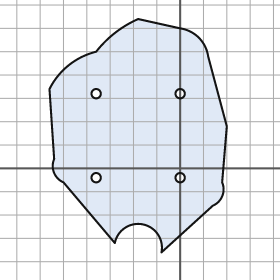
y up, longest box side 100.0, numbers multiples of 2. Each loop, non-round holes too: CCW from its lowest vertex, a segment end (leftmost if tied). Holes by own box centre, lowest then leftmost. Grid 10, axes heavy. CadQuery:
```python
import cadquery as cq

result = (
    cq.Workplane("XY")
    .moveTo(-8.0, -36.0)
    .lineTo(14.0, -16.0)
    .threePointArc((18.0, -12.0), (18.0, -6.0))
    .lineTo(20.0, 18.0)
    .lineTo(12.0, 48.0)
    .threePointArc((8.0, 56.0), (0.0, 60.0))
    .lineTo(-18.0, 64.0)
    .threePointArc((-28.0, 58.0), (-36.0, 50.0))
    .threePointArc((-48.0, 44.0), (-56.0, 34.0))
    .lineTo(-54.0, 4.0)
    .threePointArc((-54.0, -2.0), (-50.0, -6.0))
    .lineTo(-28.0, -32.0)
    .threePointArc((-16.0, -24.0), (-8.0, -36.0))
    .close()
    .moveTo(-36.0, -4.0)
    .circle(2.0)
    .moveTo(0.0, -4.0)
    .circle(2.0)
    .moveTo(-36.0, 32.0)
    .circle(2.0)
    .moveTo(0.0, 32.0)
    .circle(2.0)
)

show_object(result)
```